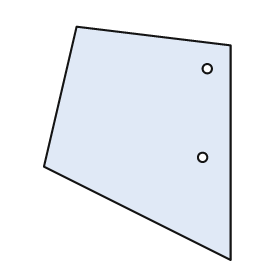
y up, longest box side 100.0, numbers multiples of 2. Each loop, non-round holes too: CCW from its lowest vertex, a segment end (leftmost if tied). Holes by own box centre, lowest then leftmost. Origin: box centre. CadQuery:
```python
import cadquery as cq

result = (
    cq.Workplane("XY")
    .moveTo(40.0, -50.0)
    .lineTo(40.0, 42.0)
    .lineTo(-26.0, 50.0)
    .lineTo(-40.0, -10.0)
    .close()
    .moveTo(28.0, -6.0)
    .circle(2.0)
    .moveTo(30.0, 32.0)
    .circle(2.0)
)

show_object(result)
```